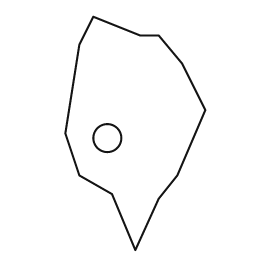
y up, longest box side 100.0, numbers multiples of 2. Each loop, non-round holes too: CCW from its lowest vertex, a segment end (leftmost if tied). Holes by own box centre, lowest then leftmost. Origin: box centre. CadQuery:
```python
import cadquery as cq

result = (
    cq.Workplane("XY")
    .moveTo(0.0, -50.0)
    .lineTo(10.0, -28.0)
    .lineTo(18.0, -18.0)
    .lineTo(30.0, 10.0)
    .lineTo(20.0, 30.0)
    .lineTo(10.0, 42.0)
    .lineTo(2.0, 42.0)
    .lineTo(-18.0, 50.0)
    .lineTo(-24.0, 38.0)
    .lineTo(-30.0, 0.0)
    .lineTo(-24.0, -18.0)
    .lineTo(-10.0, -26.0)
    .close()
    .moveTo(-12.0, -2.0)
    .circle(6.0)
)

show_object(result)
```